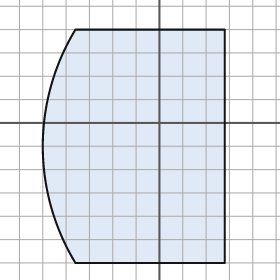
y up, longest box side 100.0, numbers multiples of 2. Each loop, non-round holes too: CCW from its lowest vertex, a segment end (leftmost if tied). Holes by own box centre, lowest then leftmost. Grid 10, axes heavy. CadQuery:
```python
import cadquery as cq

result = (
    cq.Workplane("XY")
    .moveTo(-36.0, -60.0)
    .lineTo(28.0, -60.0)
    .lineTo(28.0, 40.0)
    .lineTo(-36.0, 40.0)
    .threePointArc((-50.0, -10.0), (-36.0, -60.0))
    .close()
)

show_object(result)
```